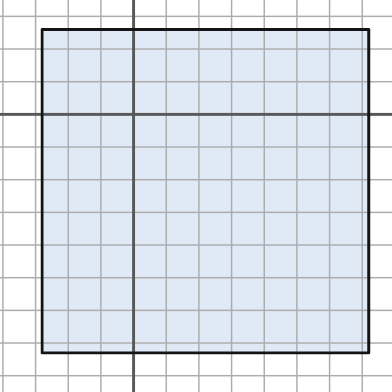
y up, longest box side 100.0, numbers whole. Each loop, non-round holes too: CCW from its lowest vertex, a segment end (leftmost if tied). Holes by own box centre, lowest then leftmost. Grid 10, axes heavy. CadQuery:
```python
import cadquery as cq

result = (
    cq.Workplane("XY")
    .moveTo(-28.0, -73.0)
    .lineTo(72.0, -73.0)
    .lineTo(72.0, 26.0)
    .lineTo(-28.0, 26.0)
    .close()
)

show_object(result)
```